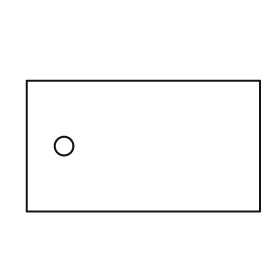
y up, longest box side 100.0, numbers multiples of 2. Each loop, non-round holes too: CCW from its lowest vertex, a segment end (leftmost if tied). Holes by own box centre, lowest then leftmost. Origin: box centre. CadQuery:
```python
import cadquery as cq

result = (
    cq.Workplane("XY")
    .moveTo(-50.0, -28.0)
    .lineTo(50.0, -28.0)
    .lineTo(50.0, 28.0)
    .lineTo(-50.0, 28.0)
    .close()
    .moveTo(-34.0, 0.0)
    .circle(4.0)
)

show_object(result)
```